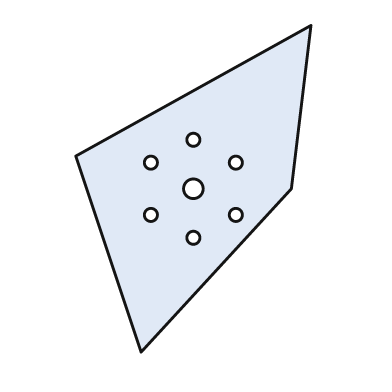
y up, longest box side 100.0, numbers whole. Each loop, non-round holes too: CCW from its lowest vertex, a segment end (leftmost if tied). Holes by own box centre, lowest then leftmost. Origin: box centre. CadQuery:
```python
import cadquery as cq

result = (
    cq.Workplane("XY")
    .moveTo(-16.0, -50.0)
    .lineTo(30.0, 0.0)
    .lineTo(36.0, 50.0)
    .lineTo(-36.0, 10.0)
    .close()
    .moveTo(0.0, -15.0)
    .circle(2.0)
    .moveTo(-13.0, -8.0)
    .circle(2.0)
    .moveTo(13.0, -8.0)
    .circle(2.0)
    .moveTo(0.0, 0.0)
    .circle(3.0)
    .moveTo(-13.0, 8.0)
    .circle(2.0)
    .moveTo(13.0, 8.0)
    .circle(2.0)
    .moveTo(0.0, 15.0)
    .circle(2.0)
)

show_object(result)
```